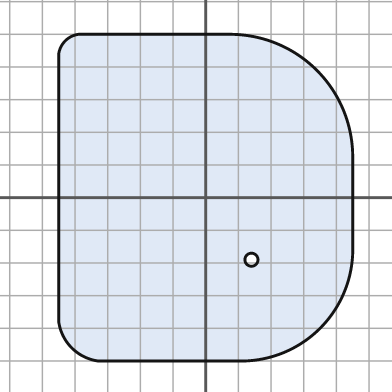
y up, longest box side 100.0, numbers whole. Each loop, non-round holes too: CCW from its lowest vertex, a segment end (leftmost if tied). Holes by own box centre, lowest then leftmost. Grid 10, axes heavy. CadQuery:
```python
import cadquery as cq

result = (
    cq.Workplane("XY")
    .moveTo(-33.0, -50.0)
    .lineTo(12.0, -50.0)
    .threePointArc((35.0, -40.0), (45.0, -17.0))
    .lineTo(45.0, 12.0)
    .threePointArc((34.0, 39.0), (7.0, 50.0))
    .lineTo(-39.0, 50.0)
    .threePointArc((-43.0, 48.0), (-45.0, 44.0))
    .lineTo(-45.0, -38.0)
    .threePointArc((-41.0, -46.0), (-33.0, -50.0))
    .close()
    .moveTo(14.0, -19.0)
    .circle(2.0)
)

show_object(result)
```